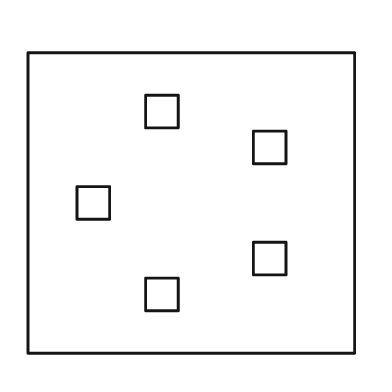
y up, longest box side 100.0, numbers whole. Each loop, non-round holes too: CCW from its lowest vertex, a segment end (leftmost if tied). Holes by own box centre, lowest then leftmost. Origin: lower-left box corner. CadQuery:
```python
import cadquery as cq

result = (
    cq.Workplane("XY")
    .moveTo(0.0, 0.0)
    .lineTo(100.0, 0.0)
    .lineTo(100.0, 92.0)
    .lineTo(0.0, 92.0)
    .close()
    .moveTo(36.0, 13.0)
    .lineTo(46.0, 13.0)
    .lineTo(46.0, 23.0)
    .lineTo(36.0, 23.0)
    .close()
    .moveTo(69.0, 24.0)
    .lineTo(79.0, 24.0)
    .lineTo(79.0, 34.0)
    .lineTo(69.0, 34.0)
    .close()
    .moveTo(15.0, 41.0)
    .lineTo(25.0, 41.0)
    .lineTo(25.0, 51.0)
    .lineTo(15.0, 51.0)
    .close()
    .moveTo(69.0, 58.0)
    .lineTo(79.0, 58.0)
    .lineTo(79.0, 68.0)
    .lineTo(69.0, 68.0)
    .close()
    .moveTo(36.0, 69.0)
    .lineTo(46.0, 69.0)
    .lineTo(46.0, 79.0)
    .lineTo(36.0, 79.0)
    .close()
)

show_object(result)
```